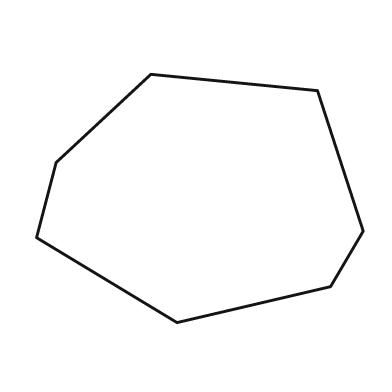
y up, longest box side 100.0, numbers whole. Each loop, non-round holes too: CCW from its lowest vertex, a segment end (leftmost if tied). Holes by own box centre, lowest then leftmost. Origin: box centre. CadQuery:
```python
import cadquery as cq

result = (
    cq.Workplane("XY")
    .moveTo(-7.0, -38.0)
    .lineTo(40.0, -27.0)
    .lineTo(50.0, -10.0)
    .lineTo(36.0, 33.0)
    .lineTo(-15.0, 38.0)
    .lineTo(-44.0, 11.0)
    .lineTo(-50.0, -12.0)
    .close()
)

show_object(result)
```